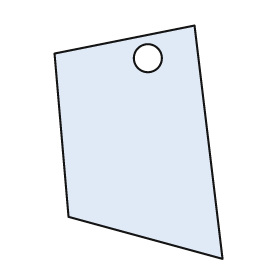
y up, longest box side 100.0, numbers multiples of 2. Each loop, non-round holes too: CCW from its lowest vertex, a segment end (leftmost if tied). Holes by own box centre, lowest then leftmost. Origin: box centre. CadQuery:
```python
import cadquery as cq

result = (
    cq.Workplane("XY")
    .moveTo(36.0, -50.0)
    .lineTo(24.0, 50.0)
    .lineTo(-36.0, 38.0)
    .lineTo(-30.0, -32.0)
    .close()
    .moveTo(4.0, 36.0)
    .circle(6.0)
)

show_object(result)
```